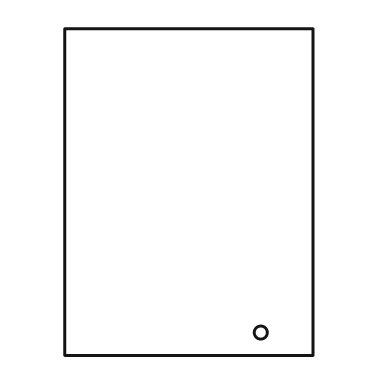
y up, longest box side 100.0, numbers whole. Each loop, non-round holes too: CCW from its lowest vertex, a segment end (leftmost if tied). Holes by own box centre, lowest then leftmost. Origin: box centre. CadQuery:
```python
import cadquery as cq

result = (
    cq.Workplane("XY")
    .moveTo(-38.0, -50.0)
    .lineTo(38.0, -50.0)
    .lineTo(38.0, 50.0)
    .lineTo(-38.0, 50.0)
    .close()
    .moveTo(22.0, -43.0)
    .circle(2.0)
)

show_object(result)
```